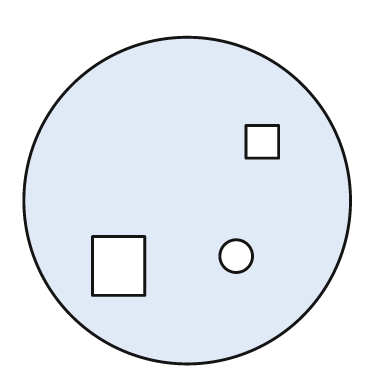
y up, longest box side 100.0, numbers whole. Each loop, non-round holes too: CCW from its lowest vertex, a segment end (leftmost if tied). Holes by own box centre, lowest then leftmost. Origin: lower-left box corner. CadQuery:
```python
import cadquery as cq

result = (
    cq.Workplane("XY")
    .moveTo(50.0, 50.0)
    .circle(50.0)
    .moveTo(21.0, 21.0)
    .lineTo(37.0, 21.0)
    .lineTo(37.0, 39.0)
    .lineTo(21.0, 39.0)
    .close()
    .moveTo(65.0, 33.0)
    .circle(5.0)
    .moveTo(68.0, 63.0)
    .lineTo(78.0, 63.0)
    .lineTo(78.0, 73.0)
    .lineTo(68.0, 73.0)
    .close()
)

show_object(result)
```